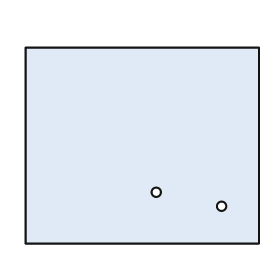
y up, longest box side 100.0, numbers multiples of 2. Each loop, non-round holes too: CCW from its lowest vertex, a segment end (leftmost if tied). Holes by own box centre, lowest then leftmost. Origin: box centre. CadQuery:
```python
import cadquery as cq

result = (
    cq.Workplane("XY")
    .moveTo(-50.0, -42.0)
    .lineTo(50.0, -42.0)
    .lineTo(50.0, 42.0)
    .lineTo(-50.0, 42.0)
    .close()
    .moveTo(34.0, -26.0)
    .circle(2.0)
    .moveTo(6.0, -20.0)
    .circle(2.0)
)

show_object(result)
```